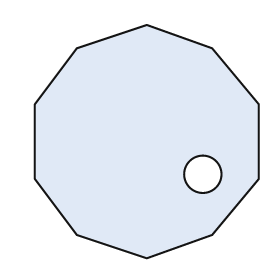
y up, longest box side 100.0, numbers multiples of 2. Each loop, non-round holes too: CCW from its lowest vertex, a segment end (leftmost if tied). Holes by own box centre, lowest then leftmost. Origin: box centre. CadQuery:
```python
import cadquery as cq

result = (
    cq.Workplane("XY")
    .moveTo(0.0, -50.0)
    .lineTo(28.0, -40.0)
    .lineTo(48.0, -16.0)
    .lineTo(48.0, 16.0)
    .lineTo(28.0, 40.0)
    .lineTo(0.0, 50.0)
    .lineTo(-30.0, 40.0)
    .lineTo(-48.0, 16.0)
    .lineTo(-48.0, -16.0)
    .lineTo(-30.0, -40.0)
    .close()
    .moveTo(24.0, -14.0)
    .circle(8.0)
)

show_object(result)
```